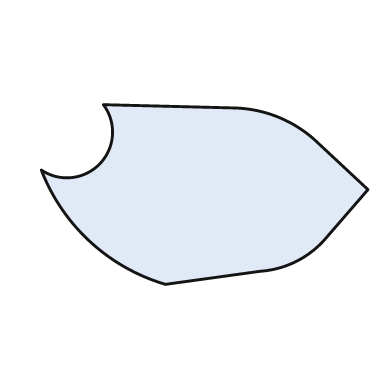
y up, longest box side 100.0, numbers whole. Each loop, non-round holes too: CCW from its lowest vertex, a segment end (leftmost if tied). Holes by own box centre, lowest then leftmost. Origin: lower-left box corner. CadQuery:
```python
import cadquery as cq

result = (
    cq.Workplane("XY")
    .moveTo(38.0, 0.0)
    .lineTo(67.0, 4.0)
    .threePointArc((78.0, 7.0), (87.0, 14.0))
    .lineTo(100.0, 29.0)
    .lineTo(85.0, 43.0)
    .threePointArc((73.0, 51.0), (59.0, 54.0))
    .lineTo(19.0, 55.0)
    .threePointArc((18.0, 37.0), (0.0, 35.0))
    .threePointArc((15.0, 13.0), (38.0, 0.0))
    .close()
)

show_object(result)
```